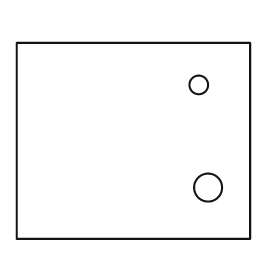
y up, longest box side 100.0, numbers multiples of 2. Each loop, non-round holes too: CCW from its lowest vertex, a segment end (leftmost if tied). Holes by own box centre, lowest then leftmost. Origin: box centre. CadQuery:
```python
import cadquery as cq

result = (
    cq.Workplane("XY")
    .moveTo(-50.0, -42.0)
    .lineTo(50.0, -42.0)
    .lineTo(50.0, 42.0)
    .lineTo(-50.0, 42.0)
    .close()
    .moveTo(32.0, -20.0)
    .circle(6.0)
    .moveTo(28.0, 24.0)
    .circle(4.0)
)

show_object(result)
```